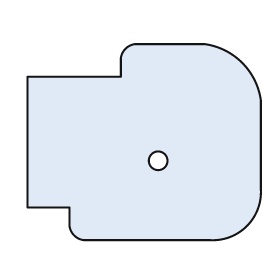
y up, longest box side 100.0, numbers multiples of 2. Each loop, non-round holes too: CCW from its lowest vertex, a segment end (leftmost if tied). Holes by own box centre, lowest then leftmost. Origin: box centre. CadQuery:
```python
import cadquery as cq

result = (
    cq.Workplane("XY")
    .moveTo(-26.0, -42.0)
    .lineTo(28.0, -42.0)
    .threePointArc((44.0, -36.0), (50.0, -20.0))
    .lineTo(50.0, 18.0)
    .threePointArc((42.0, 34.0), (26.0, 42.0))
    .lineTo(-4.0, 42.0)
    .threePointArc((-8.0, 40.0), (-10.0, 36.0))
    .lineTo(-10.0, 28.0)
    .lineTo(-50.0, 28.0)
    .lineTo(-50.0, -28.0)
    .lineTo(-32.0, -28.0)
    .lineTo(-32.0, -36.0)
    .threePointArc((-30.0, -40.0), (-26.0, -42.0))
    .close()
    .moveTo(6.0, -8.0)
    .circle(4.0)
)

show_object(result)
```